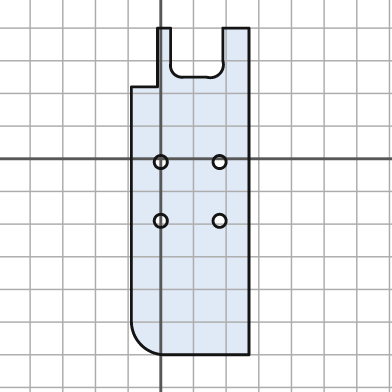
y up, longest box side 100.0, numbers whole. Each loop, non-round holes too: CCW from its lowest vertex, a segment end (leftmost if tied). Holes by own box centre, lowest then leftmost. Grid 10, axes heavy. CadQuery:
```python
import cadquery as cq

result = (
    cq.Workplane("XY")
    .moveTo(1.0, -60.0)
    .lineTo(27.0, -60.0)
    .lineTo(27.0, 40.0)
    .lineTo(19.0, 40.0)
    .lineTo(19.0, 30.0)
    .threePointArc((18.0, 26.0), (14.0, 25.0))
    .lineTo(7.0, 25.0)
    .threePointArc((4.0, 26.0), (3.0, 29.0))
    .lineTo(3.0, 40.0)
    .lineTo(-1.0, 40.0)
    .lineTo(-1.0, 22.0)
    .lineTo(-9.0, 22.0)
    .lineTo(-9.0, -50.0)
    .threePointArc((-6.0, -57.0), (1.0, -60.0))
    .close()
    .moveTo(0.0, -19.0)
    .circle(2.0)
    .moveTo(18.0, -19.0)
    .circle(2.0)
    .moveTo(0.0, -1.0)
    .circle(2.0)
    .moveTo(18.0, -1.0)
    .circle(2.0)
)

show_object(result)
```